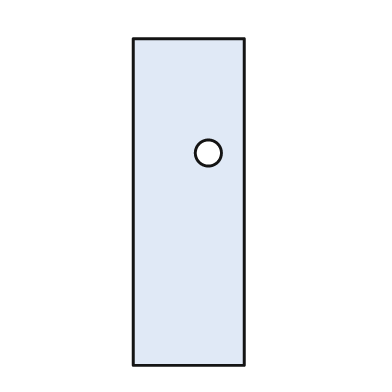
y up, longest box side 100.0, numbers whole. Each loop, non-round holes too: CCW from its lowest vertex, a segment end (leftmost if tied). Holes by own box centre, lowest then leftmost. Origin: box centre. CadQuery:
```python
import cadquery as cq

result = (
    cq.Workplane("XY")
    .moveTo(-17.0, -50.0)
    .lineTo(17.0, -50.0)
    .lineTo(17.0, 50.0)
    .lineTo(-17.0, 50.0)
    .close()
    .moveTo(6.0, 15.0)
    .circle(4.0)
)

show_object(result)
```